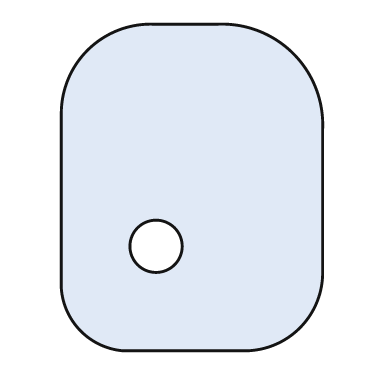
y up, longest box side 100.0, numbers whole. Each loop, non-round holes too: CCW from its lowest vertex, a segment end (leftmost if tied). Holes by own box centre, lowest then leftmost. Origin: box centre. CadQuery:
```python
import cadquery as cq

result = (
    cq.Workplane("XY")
    .moveTo(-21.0, -50.0)
    .lineTo(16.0, -50.0)
    .threePointArc((33.0, -43.0), (40.0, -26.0))
    .lineTo(40.0, 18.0)
    .threePointArc((31.0, 41.0), (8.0, 50.0))
    .lineTo(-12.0, 50.0)
    .threePointArc((-32.0, 42.0), (-40.0, 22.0))
    .lineTo(-40.0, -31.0)
    .threePointArc((-34.0, -44.0), (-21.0, -50.0))
    .close()
    .moveTo(-11.0, -18.0)
    .circle(8.0)
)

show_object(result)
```